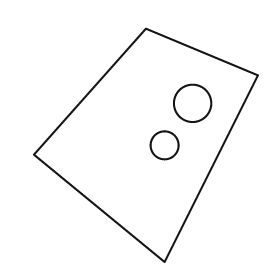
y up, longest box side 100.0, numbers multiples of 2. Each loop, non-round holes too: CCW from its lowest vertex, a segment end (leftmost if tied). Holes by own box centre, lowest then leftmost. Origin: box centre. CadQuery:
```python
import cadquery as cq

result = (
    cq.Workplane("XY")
    .moveTo(8.0, -50.0)
    .lineTo(48.0, 30.0)
    .lineTo(0.0, 50.0)
    .lineTo(-48.0, -4.0)
    .close()
    .moveTo(8.0, 0.0)
    .circle(6.0)
    .moveTo(20.0, 18.0)
    .circle(8.0)
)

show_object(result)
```